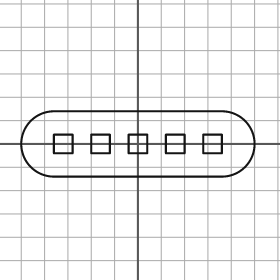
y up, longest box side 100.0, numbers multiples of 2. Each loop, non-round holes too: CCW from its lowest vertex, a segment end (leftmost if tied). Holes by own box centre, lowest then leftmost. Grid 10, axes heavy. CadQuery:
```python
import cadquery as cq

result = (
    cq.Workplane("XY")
    .moveTo(-36.0, -14.0)
    .lineTo(36.0, -14.0)
    .threePointArc((50.0, 0.0), (36.0, 14.0))
    .lineTo(-36.0, 14.0)
    .threePointArc((-50.0, 0.0), (-36.0, -14.0))
    .close()
    .moveTo(-36.0, -4.0)
    .lineTo(-28.0, -4.0)
    .lineTo(-28.0, 4.0)
    .lineTo(-36.0, 4.0)
    .close()
    .moveTo(-20.0, -4.0)
    .lineTo(-12.0, -4.0)
    .lineTo(-12.0, 4.0)
    .lineTo(-20.0, 4.0)
    .close()
    .moveTo(-4.0, -4.0)
    .lineTo(4.0, -4.0)
    .lineTo(4.0, 4.0)
    .lineTo(-4.0, 4.0)
    .close()
    .moveTo(12.0, -4.0)
    .lineTo(20.0, -4.0)
    .lineTo(20.0, 4.0)
    .lineTo(12.0, 4.0)
    .close()
    .moveTo(28.0, -4.0)
    .lineTo(36.0, -4.0)
    .lineTo(36.0, 4.0)
    .lineTo(28.0, 4.0)
    .close()
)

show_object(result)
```